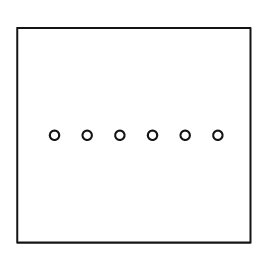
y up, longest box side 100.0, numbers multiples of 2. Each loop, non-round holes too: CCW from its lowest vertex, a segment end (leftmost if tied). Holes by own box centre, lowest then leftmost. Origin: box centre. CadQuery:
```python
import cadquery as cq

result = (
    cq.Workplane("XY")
    .moveTo(-50.0, -46.0)
    .lineTo(50.0, -46.0)
    .lineTo(50.0, 46.0)
    .lineTo(-50.0, 46.0)
    .close()
    .moveTo(-34.0, 0.0)
    .circle(2.0)
    .moveTo(-20.0, 0.0)
    .circle(2.0)
    .moveTo(-6.0, 0.0)
    .circle(2.0)
    .moveTo(8.0, 0.0)
    .circle(2.0)
    .moveTo(22.0, 0.0)
    .circle(2.0)
    .moveTo(36.0, 0.0)
    .circle(2.0)
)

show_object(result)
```